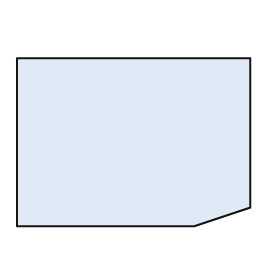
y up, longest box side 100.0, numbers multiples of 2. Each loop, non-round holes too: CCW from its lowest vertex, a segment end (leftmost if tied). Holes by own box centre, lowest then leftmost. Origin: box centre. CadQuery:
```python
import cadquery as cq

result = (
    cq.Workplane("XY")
    .moveTo(-50.0, -36.0)
    .lineTo(26.0, -36.0)
    .lineTo(50.0, -28.0)
    .lineTo(50.0, 36.0)
    .lineTo(-50.0, 36.0)
    .close()
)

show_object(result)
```